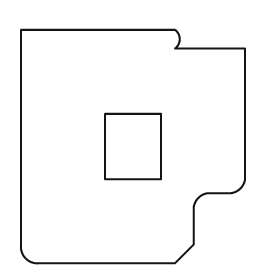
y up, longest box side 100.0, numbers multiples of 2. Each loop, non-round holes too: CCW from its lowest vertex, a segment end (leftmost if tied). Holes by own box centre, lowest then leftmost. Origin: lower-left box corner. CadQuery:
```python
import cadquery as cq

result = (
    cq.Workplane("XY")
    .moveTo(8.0, 0.0)
    .lineTo(66.0, 0.0)
    .lineTo(74.0, 8.0)
    .lineTo(74.0, 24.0)
    .threePointArc((76.0, 28.0), (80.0, 30.0))
    .lineTo(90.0, 30.0)
    .threePointArc((94.0, 32.0), (96.0, 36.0))
    .lineTo(96.0, 92.0)
    .lineTo(66.0, 92.0)
    .threePointArc((68.0, 96.0), (66.0, 100.0))
    .lineTo(0.0, 100.0)
    .lineTo(0.0, 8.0)
    .threePointArc((2.0, 2.0), (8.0, 0.0))
    .close()
    .moveTo(36.0, 36.0)
    .lineTo(60.0, 36.0)
    .lineTo(60.0, 64.0)
    .lineTo(36.0, 64.0)
    .close()
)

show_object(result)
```